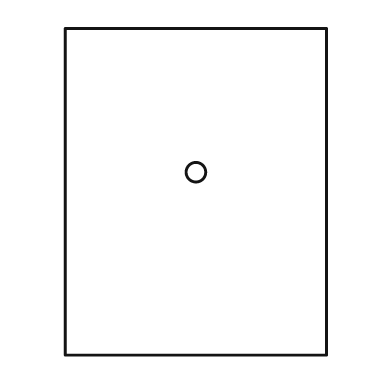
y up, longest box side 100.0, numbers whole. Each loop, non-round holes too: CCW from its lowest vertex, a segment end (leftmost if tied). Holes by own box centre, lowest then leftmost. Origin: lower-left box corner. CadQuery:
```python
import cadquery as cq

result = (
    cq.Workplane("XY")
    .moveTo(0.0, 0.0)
    .lineTo(80.0, 0.0)
    .lineTo(80.0, 100.0)
    .lineTo(0.0, 100.0)
    .close()
    .moveTo(40.0, 56.0)
    .circle(3.0)
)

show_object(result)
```